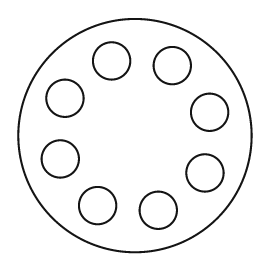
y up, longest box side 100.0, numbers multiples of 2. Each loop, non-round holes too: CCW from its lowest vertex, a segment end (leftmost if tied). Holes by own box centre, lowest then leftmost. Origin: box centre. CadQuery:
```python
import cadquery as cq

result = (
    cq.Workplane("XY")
    .moveTo(0.0, 0.0)
    .circle(50.0)
    .moveTo(10.0, -32.0)
    .circle(8.0)
    .moveTo(-16.0, -30.0)
    .circle(8.0)
    .moveTo(30.0, -16.0)
    .circle(8.0)
    .moveTo(-32.0, -10.0)
    .circle(8.0)
    .moveTo(32.0, 10.0)
    .circle(8.0)
    .moveTo(-30.0, 16.0)
    .circle(8.0)
    .moveTo(16.0, 30.0)
    .circle(8.0)
    .moveTo(-10.0, 32.0)
    .circle(8.0)
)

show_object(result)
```